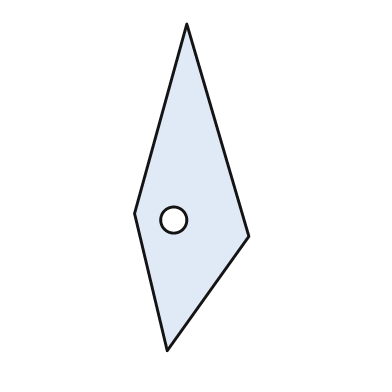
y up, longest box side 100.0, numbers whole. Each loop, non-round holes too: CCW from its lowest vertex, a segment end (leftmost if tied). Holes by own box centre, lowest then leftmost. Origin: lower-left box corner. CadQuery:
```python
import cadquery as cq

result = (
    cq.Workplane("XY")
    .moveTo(10.0, 0.0)
    .lineTo(35.0, 35.0)
    .lineTo(16.0, 100.0)
    .lineTo(0.0, 42.0)
    .close()
    .moveTo(12.0, 40.0)
    .circle(4.0)
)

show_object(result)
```